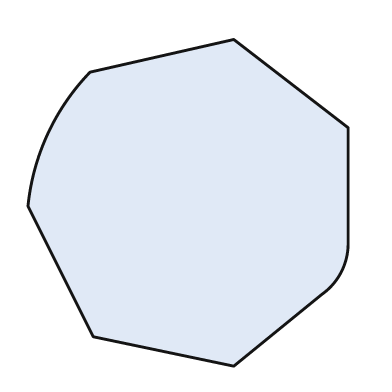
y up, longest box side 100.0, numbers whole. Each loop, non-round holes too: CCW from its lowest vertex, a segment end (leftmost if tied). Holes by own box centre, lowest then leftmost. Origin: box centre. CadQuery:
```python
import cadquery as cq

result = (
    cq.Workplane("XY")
    .moveTo(14.0, -50.0)
    .lineTo(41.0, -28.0)
    .threePointArc((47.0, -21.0), (49.0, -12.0))
    .lineTo(49.0, 23.0)
    .lineTo(14.0, 50.0)
    .lineTo(-30.0, 40.0)
    .threePointArc((-43.0, 21.0), (-49.0, -1.0))
    .lineTo(-29.0, -41.0)
    .close()
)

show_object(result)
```